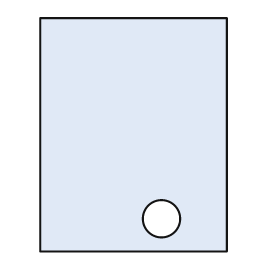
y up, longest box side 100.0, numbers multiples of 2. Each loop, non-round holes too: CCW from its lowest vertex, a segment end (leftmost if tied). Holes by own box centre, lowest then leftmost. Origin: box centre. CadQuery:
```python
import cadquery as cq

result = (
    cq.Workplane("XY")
    .moveTo(-40.0, -50.0)
    .lineTo(40.0, -50.0)
    .lineTo(40.0, 50.0)
    .lineTo(-40.0, 50.0)
    .close()
    .moveTo(12.0, -36.0)
    .circle(8.0)
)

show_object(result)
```